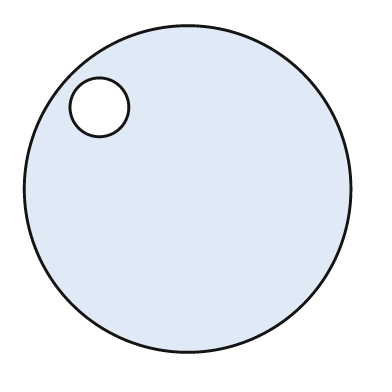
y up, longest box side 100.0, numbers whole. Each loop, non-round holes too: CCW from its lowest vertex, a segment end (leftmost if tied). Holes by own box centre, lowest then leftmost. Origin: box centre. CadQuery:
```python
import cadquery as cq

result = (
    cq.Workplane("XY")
    .moveTo(0.0, 0.0)
    .circle(50.0)
    .moveTo(-27.0, 25.0)
    .circle(9.0)
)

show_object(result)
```